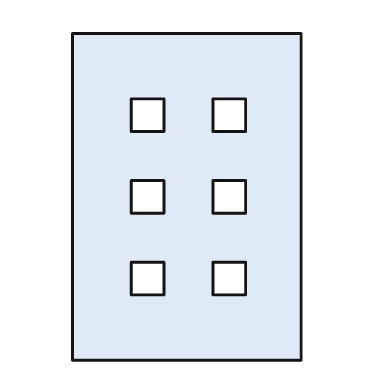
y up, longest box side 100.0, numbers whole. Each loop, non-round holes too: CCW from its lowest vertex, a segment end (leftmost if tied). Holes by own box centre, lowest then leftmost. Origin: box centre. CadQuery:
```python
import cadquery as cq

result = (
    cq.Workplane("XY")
    .moveTo(-35.0, -50.0)
    .lineTo(35.0, -50.0)
    .lineTo(35.0, 50.0)
    .lineTo(-35.0, 50.0)
    .close()
    .moveTo(-17.0, -30.0)
    .lineTo(-7.0, -30.0)
    .lineTo(-7.0, -20.0)
    .lineTo(-17.0, -20.0)
    .close()
    .moveTo(8.0, -30.0)
    .lineTo(18.0, -30.0)
    .lineTo(18.0, -20.0)
    .lineTo(8.0, -20.0)
    .close()
    .moveTo(-17.0, -5.0)
    .lineTo(-7.0, -5.0)
    .lineTo(-7.0, 5.0)
    .lineTo(-17.0, 5.0)
    .close()
    .moveTo(8.0, -5.0)
    .lineTo(18.0, -5.0)
    .lineTo(18.0, 5.0)
    .lineTo(8.0, 5.0)
    .close()
    .moveTo(-17.0, 20.0)
    .lineTo(-7.0, 20.0)
    .lineTo(-7.0, 30.0)
    .lineTo(-17.0, 30.0)
    .close()
    .moveTo(8.0, 20.0)
    .lineTo(18.0, 20.0)
    .lineTo(18.0, 30.0)
    .lineTo(8.0, 30.0)
    .close()
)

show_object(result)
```